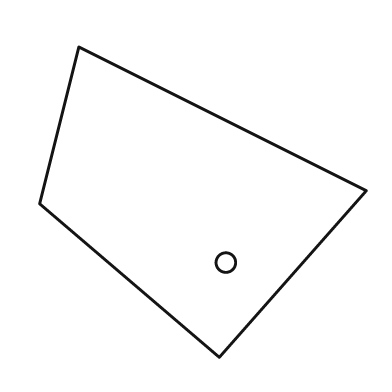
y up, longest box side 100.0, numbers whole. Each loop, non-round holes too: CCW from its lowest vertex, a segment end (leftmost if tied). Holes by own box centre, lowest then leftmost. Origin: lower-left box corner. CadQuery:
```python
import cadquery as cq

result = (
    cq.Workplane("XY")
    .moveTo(55.0, 0.0)
    .lineTo(100.0, 51.0)
    .lineTo(12.0, 95.0)
    .lineTo(0.0, 47.0)
    .close()
    .moveTo(57.0, 29.0)
    .circle(3.0)
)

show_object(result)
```